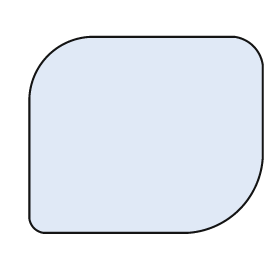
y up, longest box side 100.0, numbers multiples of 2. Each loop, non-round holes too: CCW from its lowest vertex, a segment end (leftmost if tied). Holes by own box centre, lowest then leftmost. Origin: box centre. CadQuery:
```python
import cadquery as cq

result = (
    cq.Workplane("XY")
    .moveTo(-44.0, -42.0)
    .lineTo(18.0, -42.0)
    .threePointArc((40.0, -32.0), (50.0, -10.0))
    .lineTo(50.0, 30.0)
    .threePointArc((46.0, 38.0), (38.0, 42.0))
    .lineTo(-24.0, 42.0)
    .threePointArc((-42.0, 34.0), (-50.0, 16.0))
    .lineTo(-50.0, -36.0)
    .threePointArc((-48.0, -40.0), (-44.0, -42.0))
    .close()
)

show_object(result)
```